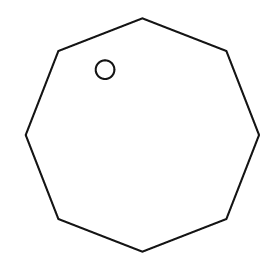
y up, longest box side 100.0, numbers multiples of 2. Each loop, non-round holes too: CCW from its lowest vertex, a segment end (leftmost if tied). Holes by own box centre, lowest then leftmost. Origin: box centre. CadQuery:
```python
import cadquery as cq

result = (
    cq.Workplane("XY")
    .moveTo(0.0, -50.0)
    .lineTo(36.0, -36.0)
    .lineTo(50.0, 0.0)
    .lineTo(36.0, 36.0)
    .lineTo(0.0, 50.0)
    .lineTo(-36.0, 36.0)
    .lineTo(-50.0, 0.0)
    .lineTo(-36.0, -36.0)
    .close()
    .moveTo(-16.0, 28.0)
    .circle(4.0)
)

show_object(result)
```